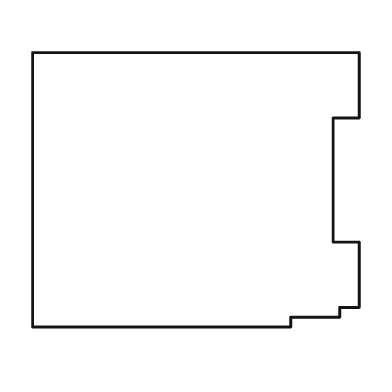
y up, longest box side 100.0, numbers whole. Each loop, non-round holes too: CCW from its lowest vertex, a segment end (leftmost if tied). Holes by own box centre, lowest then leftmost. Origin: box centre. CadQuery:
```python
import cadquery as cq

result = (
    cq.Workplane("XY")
    .moveTo(-50.0, -42.0)
    .lineTo(29.0, -42.0)
    .lineTo(29.0, -39.0)
    .lineTo(44.0, -39.0)
    .lineTo(44.0, -36.0)
    .lineTo(50.0, -36.0)
    .lineTo(50.0, -16.0)
    .lineTo(42.0, -16.0)
    .lineTo(42.0, 22.0)
    .lineTo(50.0, 22.0)
    .lineTo(50.0, 42.0)
    .lineTo(-50.0, 42.0)
    .close()
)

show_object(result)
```